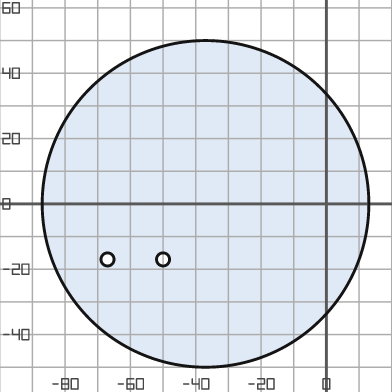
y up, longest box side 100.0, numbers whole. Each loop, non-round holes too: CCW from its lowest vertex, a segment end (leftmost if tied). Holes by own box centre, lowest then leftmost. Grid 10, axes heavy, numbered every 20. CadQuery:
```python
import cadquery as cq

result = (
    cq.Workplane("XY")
    .moveTo(-37.0, 0.0)
    .circle(50.0)
    .moveTo(-67.0, -17.0)
    .circle(2.0)
    .moveTo(-50.0, -17.0)
    .circle(2.0)
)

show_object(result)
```